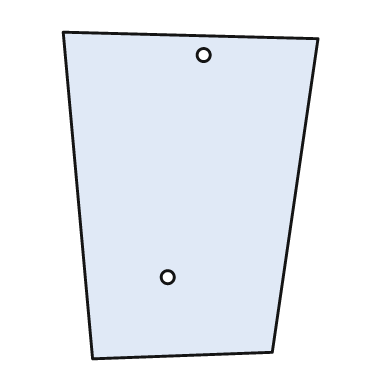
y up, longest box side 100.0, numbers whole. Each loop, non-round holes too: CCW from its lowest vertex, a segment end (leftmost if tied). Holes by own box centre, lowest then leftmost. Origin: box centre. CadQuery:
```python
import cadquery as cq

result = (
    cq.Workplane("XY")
    .moveTo(-30.0, -50.0)
    .lineTo(25.0, -48.0)
    .lineTo(39.0, 48.0)
    .lineTo(-39.0, 50.0)
    .close()
    .moveTo(-7.0, -25.0)
    .circle(2.0)
    .moveTo(4.0, 43.0)
    .circle(2.0)
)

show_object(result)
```